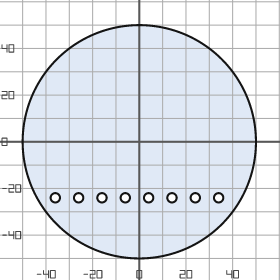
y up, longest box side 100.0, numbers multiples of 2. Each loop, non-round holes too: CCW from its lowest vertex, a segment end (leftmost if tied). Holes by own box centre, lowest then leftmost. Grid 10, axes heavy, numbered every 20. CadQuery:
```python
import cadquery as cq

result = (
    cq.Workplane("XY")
    .moveTo(0.0, 0.0)
    .circle(50.0)
    .moveTo(-36.0, -24.0)
    .circle(2.0)
    .moveTo(-26.0, -24.0)
    .circle(2.0)
    .moveTo(-16.0, -24.0)
    .circle(2.0)
    .moveTo(-6.0, -24.0)
    .circle(2.0)
    .moveTo(4.0, -24.0)
    .circle(2.0)
    .moveTo(14.0, -24.0)
    .circle(2.0)
    .moveTo(24.0, -24.0)
    .circle(2.0)
    .moveTo(34.0, -24.0)
    .circle(2.0)
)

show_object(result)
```